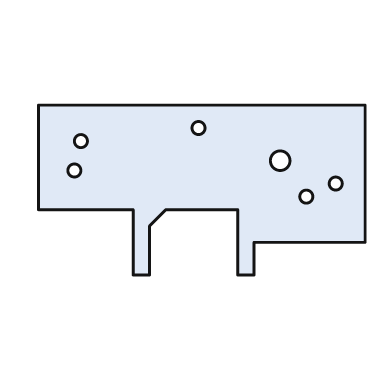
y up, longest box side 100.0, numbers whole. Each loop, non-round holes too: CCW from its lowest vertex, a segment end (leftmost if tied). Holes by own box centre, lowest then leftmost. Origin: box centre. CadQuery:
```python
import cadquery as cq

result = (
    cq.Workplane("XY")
    .moveTo(-21.0, -26.0)
    .lineTo(-16.0, -26.0)
    .lineTo(-16.0, -11.0)
    .lineTo(-11.0, -6.0)
    .lineTo(11.0, -6.0)
    .lineTo(11.0, -26.0)
    .lineTo(16.0, -26.0)
    .lineTo(16.0, -16.0)
    .lineTo(50.0, -16.0)
    .lineTo(50.0, 26.0)
    .lineTo(-50.0, 26.0)
    .lineTo(-50.0, -6.0)
    .lineTo(-21.0, -6.0)
    .close()
    .moveTo(32.0, -2.0)
    .circle(2.0)
    .moveTo(41.0, 2.0)
    .circle(2.0)
    .moveTo(-39.0, 6.0)
    .circle(2.0)
    .moveTo(24.0, 9.0)
    .circle(3.0)
    .moveTo(-37.0, 15.0)
    .circle(2.0)
    .moveTo(-1.0, 19.0)
    .circle(2.0)
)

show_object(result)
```